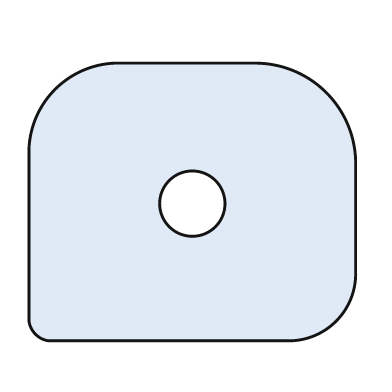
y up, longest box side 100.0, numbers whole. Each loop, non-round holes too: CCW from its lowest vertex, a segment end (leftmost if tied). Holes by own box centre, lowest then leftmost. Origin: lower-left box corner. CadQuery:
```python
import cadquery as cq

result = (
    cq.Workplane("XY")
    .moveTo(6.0, 0.0)
    .lineTo(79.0, 0.0)
    .threePointArc((94.0, 6.0), (100.0, 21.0))
    .lineTo(100.0, 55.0)
    .threePointArc((91.0, 76.0), (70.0, 85.0))
    .lineTo(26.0, 85.0)
    .threePointArc((8.0, 77.0), (0.0, 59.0))
    .lineTo(0.0, 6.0)
    .threePointArc((2.0, 2.0), (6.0, 0.0))
    .close()
    .moveTo(50.0, 42.0)
    .circle(10.0)
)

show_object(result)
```